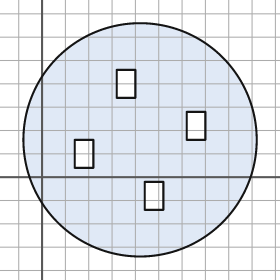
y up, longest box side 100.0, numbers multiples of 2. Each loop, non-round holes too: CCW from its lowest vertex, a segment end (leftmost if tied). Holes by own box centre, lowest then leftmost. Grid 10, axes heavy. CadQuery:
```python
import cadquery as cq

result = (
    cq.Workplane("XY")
    .moveTo(42.0, 16.0)
    .circle(50.0)
    .moveTo(44.0, -14.0)
    .lineTo(52.0, -14.0)
    .lineTo(52.0, -2.0)
    .lineTo(44.0, -2.0)
    .close()
    .moveTo(14.0, 4.0)
    .lineTo(22.0, 4.0)
    .lineTo(22.0, 16.0)
    .lineTo(14.0, 16.0)
    .close()
    .moveTo(62.0, 16.0)
    .lineTo(70.0, 16.0)
    .lineTo(70.0, 28.0)
    .lineTo(62.0, 28.0)
    .close()
    .moveTo(32.0, 34.0)
    .lineTo(40.0, 34.0)
    .lineTo(40.0, 46.0)
    .lineTo(32.0, 46.0)
    .close()
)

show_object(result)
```